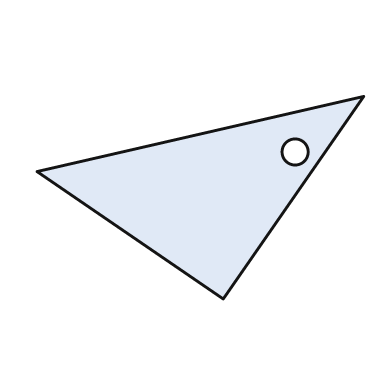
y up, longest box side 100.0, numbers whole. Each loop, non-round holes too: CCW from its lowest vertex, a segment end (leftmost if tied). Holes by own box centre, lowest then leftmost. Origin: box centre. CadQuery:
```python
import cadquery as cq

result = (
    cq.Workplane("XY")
    .moveTo(7.0, -31.0)
    .lineTo(50.0, 31.0)
    .lineTo(-50.0, 8.0)
    .close()
    .moveTo(29.0, 14.0)
    .circle(4.0)
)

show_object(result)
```